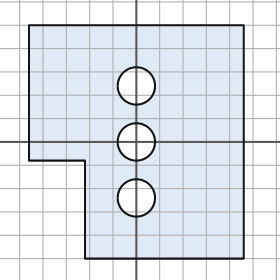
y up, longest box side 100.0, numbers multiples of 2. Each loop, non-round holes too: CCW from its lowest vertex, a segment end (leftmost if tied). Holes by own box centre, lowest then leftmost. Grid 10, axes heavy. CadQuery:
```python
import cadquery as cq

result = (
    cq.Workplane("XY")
    .moveTo(-22.0, -50.0)
    .lineTo(46.0, -50.0)
    .lineTo(46.0, 50.0)
    .lineTo(-46.0, 50.0)
    .lineTo(-46.0, -8.0)
    .lineTo(-22.0, -8.0)
    .close()
    .moveTo(0.0, -24.0)
    .circle(8.0)
    .moveTo(0.0, 0.0)
    .circle(8.0)
    .moveTo(0.0, 24.0)
    .circle(8.0)
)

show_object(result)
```